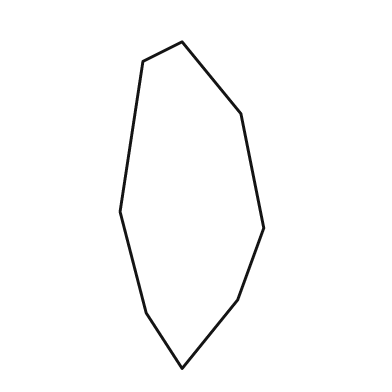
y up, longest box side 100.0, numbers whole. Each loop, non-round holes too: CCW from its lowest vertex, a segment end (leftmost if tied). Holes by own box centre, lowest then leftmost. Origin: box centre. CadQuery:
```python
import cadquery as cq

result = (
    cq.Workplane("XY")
    .moveTo(-3.0, -50.0)
    .lineTo(14.0, -29.0)
    .lineTo(22.0, -7.0)
    .lineTo(15.0, 28.0)
    .lineTo(-3.0, 50.0)
    .lineTo(-15.0, 44.0)
    .lineTo(-22.0, -2.0)
    .lineTo(-14.0, -33.0)
    .close()
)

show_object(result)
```